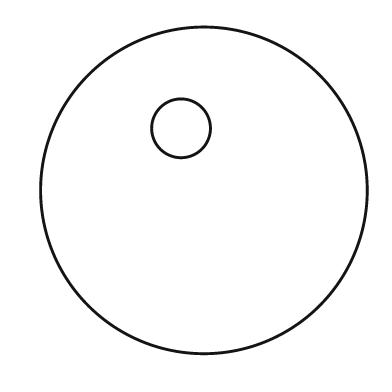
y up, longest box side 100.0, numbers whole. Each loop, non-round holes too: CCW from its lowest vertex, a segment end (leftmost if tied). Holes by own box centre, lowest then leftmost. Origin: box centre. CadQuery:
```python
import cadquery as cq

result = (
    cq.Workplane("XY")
    .moveTo(0.0, 0.0)
    .circle(50.0)
    .moveTo(-7.0, 19.0)
    .circle(9.0)
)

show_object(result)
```